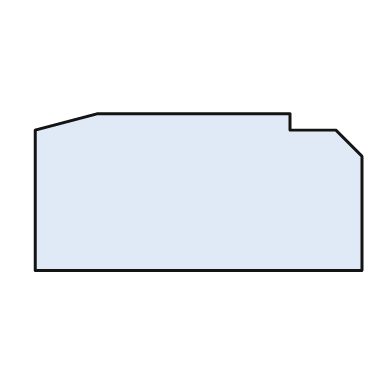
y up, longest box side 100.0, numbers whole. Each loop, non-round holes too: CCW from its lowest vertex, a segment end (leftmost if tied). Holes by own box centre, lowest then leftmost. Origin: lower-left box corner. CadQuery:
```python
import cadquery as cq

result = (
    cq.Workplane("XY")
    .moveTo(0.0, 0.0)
    .lineTo(100.0, 0.0)
    .lineTo(100.0, 35.0)
    .lineTo(92.0, 43.0)
    .lineTo(78.0, 43.0)
    .lineTo(78.0, 48.0)
    .lineTo(19.0, 48.0)
    .lineTo(0.0, 43.0)
    .close()
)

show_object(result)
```